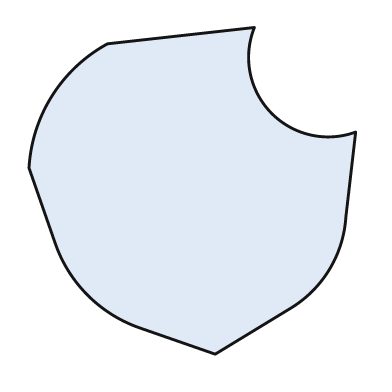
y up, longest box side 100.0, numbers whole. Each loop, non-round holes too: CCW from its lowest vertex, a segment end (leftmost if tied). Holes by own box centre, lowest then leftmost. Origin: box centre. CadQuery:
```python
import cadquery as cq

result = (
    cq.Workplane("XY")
    .moveTo(7.0, -50.0)
    .lineTo(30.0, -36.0)
    .threePointArc((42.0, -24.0), (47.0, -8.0))
    .lineTo(50.0, 18.0)
    .threePointArc((24.0, 24.0), (19.0, 50.0))
    .lineTo(-26.0, 45.0)
    .threePointArc((-43.0, 29.0), (-50.0, 7.0))
    .lineTo(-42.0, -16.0)
    .threePointArc((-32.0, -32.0), (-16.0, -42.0))
    .close()
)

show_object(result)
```